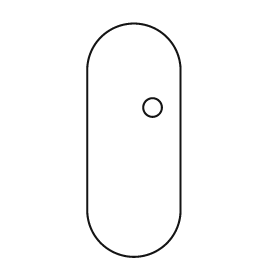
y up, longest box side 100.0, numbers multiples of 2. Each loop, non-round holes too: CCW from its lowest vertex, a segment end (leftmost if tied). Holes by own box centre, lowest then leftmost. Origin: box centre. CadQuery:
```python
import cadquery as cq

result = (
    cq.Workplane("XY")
    .moveTo(-20.0, -30.0)
    .threePointArc((0.0, -50.0), (20.0, -30.0))
    .lineTo(20.0, 30.0)
    .threePointArc((0.0, 50.0), (-20.0, 30.0))
    .close()
    .moveTo(8.0, 14.0)
    .circle(4.0)
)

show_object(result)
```